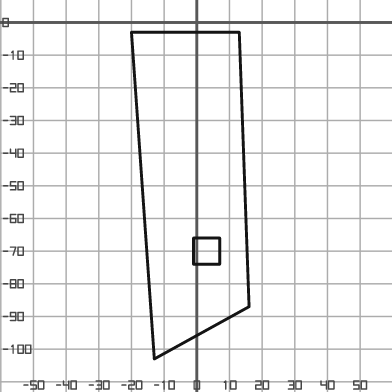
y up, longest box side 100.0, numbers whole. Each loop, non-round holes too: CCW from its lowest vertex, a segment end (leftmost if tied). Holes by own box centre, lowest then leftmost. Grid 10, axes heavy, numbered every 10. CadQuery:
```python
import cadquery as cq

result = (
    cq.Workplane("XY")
    .moveTo(-13.0, -103.0)
    .lineTo(16.0, -87.0)
    .lineTo(13.0, -3.0)
    .lineTo(-20.0, -3.0)
    .close()
    .moveTo(-1.0, -74.0)
    .lineTo(7.0, -74.0)
    .lineTo(7.0, -66.0)
    .lineTo(-1.0, -66.0)
    .close()
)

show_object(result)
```